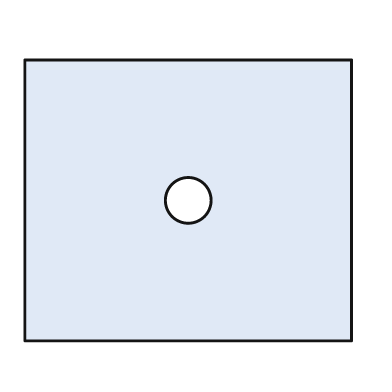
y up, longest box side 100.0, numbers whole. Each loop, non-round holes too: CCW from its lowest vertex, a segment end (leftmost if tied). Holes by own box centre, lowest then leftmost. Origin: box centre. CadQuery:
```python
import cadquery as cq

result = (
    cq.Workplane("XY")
    .moveTo(-50.0, -43.0)
    .lineTo(50.0, -43.0)
    .lineTo(50.0, 43.0)
    .lineTo(-50.0, 43.0)
    .close()
    .moveTo(0.0, 0.0)
    .circle(7.0)
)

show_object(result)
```